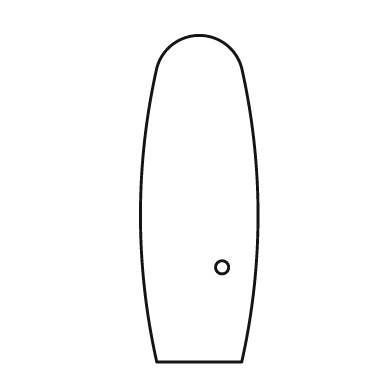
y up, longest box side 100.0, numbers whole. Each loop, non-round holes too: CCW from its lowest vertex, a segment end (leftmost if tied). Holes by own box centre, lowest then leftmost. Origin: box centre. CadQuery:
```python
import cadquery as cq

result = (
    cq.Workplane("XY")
    .moveTo(-13.0, -50.0)
    .lineTo(13.0, -50.0)
    .threePointArc((18.0, -5.0), (13.0, 40.0))
    .threePointArc((0.0, 50.0), (-13.0, 40.0))
    .threePointArc((-18.0, -5.0), (-13.0, -50.0))
    .close()
    .moveTo(7.0, -21.0)
    .circle(2.0)
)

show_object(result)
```